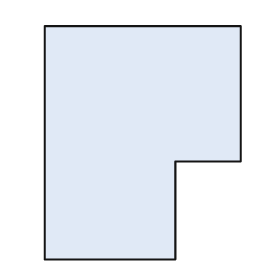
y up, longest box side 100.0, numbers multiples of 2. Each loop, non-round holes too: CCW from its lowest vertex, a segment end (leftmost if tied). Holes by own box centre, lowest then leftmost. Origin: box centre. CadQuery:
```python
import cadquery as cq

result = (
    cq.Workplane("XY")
    .moveTo(-42.0, -50.0)
    .lineTo(14.0, -50.0)
    .lineTo(14.0, -8.0)
    .lineTo(42.0, -8.0)
    .lineTo(42.0, 50.0)
    .lineTo(-42.0, 50.0)
    .close()
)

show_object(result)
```